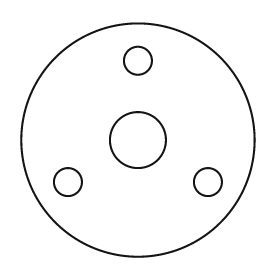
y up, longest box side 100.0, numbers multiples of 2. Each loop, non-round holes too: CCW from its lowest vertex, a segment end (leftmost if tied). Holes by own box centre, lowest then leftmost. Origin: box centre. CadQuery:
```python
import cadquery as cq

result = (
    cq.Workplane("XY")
    .moveTo(0.0, 0.0)
    .circle(50.0)
    .moveTo(-30.0, -18.0)
    .circle(6.0)
    .moveTo(30.0, -18.0)
    .circle(6.0)
    .moveTo(0.0, 0.0)
    .circle(12.0)
    .moveTo(0.0, 34.0)
    .circle(6.0)
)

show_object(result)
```